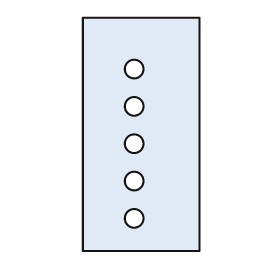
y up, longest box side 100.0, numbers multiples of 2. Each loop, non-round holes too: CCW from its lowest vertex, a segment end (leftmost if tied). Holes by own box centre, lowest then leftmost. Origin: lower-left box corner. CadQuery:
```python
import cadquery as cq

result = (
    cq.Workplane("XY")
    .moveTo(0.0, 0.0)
    .lineTo(50.0, 0.0)
    .lineTo(50.0, 100.0)
    .lineTo(0.0, 100.0)
    .close()
    .moveTo(22.0, 14.0)
    .circle(4.0)
    .moveTo(22.0, 30.0)
    .circle(4.0)
    .moveTo(22.0, 46.0)
    .circle(4.0)
    .moveTo(22.0, 62.0)
    .circle(4.0)
    .moveTo(22.0, 78.0)
    .circle(4.0)
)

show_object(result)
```